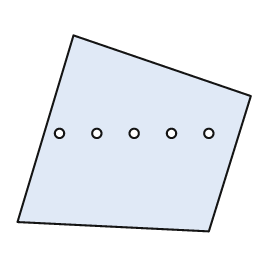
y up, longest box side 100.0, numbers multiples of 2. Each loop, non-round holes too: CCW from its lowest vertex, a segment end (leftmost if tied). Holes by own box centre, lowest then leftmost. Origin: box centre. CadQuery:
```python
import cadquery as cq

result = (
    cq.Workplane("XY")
    .moveTo(32.0, -42.0)
    .lineTo(50.0, 16.0)
    .lineTo(-26.0, 42.0)
    .lineTo(-50.0, -38.0)
    .close()
    .moveTo(-32.0, 0.0)
    .circle(2.0)
    .moveTo(-16.0, 0.0)
    .circle(2.0)
    .moveTo(0.0, 0.0)
    .circle(2.0)
    .moveTo(16.0, 0.0)
    .circle(2.0)
    .moveTo(32.0, 0.0)
    .circle(2.0)
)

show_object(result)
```